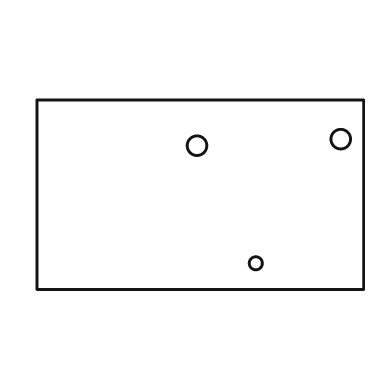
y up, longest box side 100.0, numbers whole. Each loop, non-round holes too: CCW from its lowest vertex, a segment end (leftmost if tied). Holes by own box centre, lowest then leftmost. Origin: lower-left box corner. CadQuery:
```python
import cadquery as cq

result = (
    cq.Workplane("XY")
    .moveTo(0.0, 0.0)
    .lineTo(100.0, 0.0)
    .lineTo(100.0, 58.0)
    .lineTo(0.0, 58.0)
    .close()
    .moveTo(67.0, 8.0)
    .circle(2.0)
    .moveTo(49.0, 44.0)
    .circle(3.0)
    .moveTo(93.0, 46.0)
    .circle(3.0)
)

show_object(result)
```